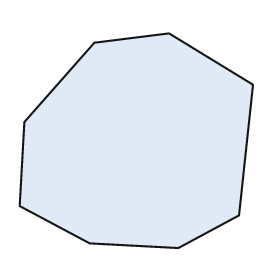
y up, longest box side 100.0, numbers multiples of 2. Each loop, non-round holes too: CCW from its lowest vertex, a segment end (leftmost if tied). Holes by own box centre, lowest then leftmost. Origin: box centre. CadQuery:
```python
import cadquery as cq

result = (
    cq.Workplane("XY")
    .moveTo(18.0, -46.0)
    .lineTo(44.0, -32.0)
    .lineTo(50.0, 24.0)
    .lineTo(14.0, 46.0)
    .lineTo(-18.0, 42.0)
    .lineTo(-48.0, 8.0)
    .lineTo(-50.0, -28.0)
    .lineTo(-20.0, -44.0)
    .close()
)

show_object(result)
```